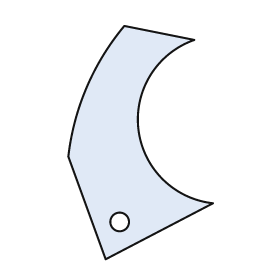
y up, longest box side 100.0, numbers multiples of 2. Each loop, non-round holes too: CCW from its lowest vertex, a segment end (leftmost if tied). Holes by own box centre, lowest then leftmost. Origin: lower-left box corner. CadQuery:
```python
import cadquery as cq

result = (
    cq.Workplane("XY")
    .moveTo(16.0, 0.0)
    .lineTo(62.0, 24.0)
    .threePointArc((30.0, 56.0), (54.0, 94.0))
    .lineTo(24.0, 100.0)
    .threePointArc((8.0, 74.0), (0.0, 44.0))
    .close()
    .moveTo(22.0, 16.0)
    .circle(4.0)
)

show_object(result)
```